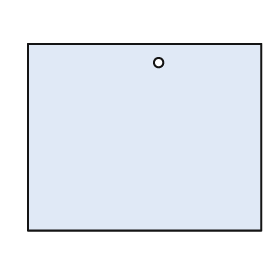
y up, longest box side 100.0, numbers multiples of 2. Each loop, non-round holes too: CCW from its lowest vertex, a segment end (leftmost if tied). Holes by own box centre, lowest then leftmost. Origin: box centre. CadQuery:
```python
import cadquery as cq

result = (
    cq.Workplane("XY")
    .moveTo(-50.0, -40.0)
    .lineTo(50.0, -40.0)
    .lineTo(50.0, 40.0)
    .lineTo(-50.0, 40.0)
    .close()
    .moveTo(6.0, 32.0)
    .circle(2.0)
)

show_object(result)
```